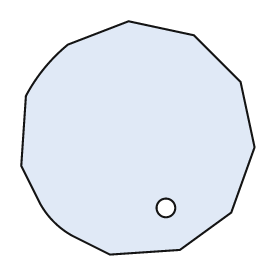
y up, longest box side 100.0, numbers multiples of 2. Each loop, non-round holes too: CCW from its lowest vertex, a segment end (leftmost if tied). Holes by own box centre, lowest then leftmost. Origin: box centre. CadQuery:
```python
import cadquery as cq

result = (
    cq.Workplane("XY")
    .moveTo(-12.0, -50.0)
    .lineTo(18.0, -48.0)
    .lineTo(40.0, -32.0)
    .lineTo(50.0, -4.0)
    .lineTo(44.0, 24.0)
    .lineTo(24.0, 44.0)
    .lineTo(-4.0, 50.0)
    .lineTo(-30.0, 40.0)
    .threePointArc((-40.0, 30.0), (-48.0, 18.0))
    .lineTo(-50.0, -12.0)
    .lineTo(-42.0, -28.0)
    .threePointArc((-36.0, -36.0), (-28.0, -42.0))
    .close()
    .moveTo(12.0, -30.0)
    .circle(4.0)
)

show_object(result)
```